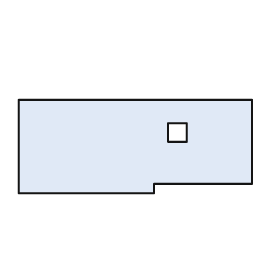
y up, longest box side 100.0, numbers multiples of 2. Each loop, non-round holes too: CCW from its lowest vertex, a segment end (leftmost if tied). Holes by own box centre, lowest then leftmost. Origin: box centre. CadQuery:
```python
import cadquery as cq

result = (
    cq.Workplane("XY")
    .moveTo(-50.0, -20.0)
    .lineTo(8.0, -20.0)
    .lineTo(8.0, -16.0)
    .lineTo(50.0, -16.0)
    .lineTo(50.0, 20.0)
    .lineTo(-50.0, 20.0)
    .close()
    .moveTo(14.0, 2.0)
    .lineTo(22.0, 2.0)
    .lineTo(22.0, 10.0)
    .lineTo(14.0, 10.0)
    .close()
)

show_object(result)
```